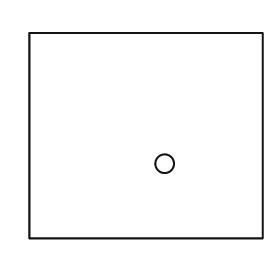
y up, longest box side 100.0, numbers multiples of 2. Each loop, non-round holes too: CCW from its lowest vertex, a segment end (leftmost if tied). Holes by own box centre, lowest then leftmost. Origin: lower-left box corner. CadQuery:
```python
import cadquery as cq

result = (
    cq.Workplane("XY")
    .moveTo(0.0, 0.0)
    .lineTo(100.0, 0.0)
    .lineTo(100.0, 88.0)
    .lineTo(0.0, 88.0)
    .close()
    .moveTo(58.0, 32.0)
    .circle(4.0)
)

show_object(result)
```